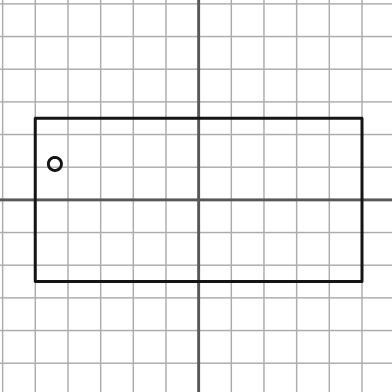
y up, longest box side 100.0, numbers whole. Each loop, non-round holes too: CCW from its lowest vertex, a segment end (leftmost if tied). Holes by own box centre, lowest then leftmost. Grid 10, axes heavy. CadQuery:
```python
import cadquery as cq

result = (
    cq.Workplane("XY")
    .moveTo(-50.0, -25.0)
    .lineTo(50.0, -25.0)
    .lineTo(50.0, 25.0)
    .lineTo(-50.0, 25.0)
    .close()
    .moveTo(-44.0, 11.0)
    .circle(2.0)
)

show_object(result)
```